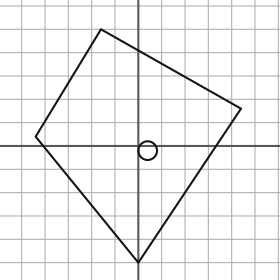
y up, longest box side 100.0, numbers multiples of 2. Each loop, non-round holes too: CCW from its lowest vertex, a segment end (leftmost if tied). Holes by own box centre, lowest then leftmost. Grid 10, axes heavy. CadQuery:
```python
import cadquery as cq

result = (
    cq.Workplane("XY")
    .moveTo(0.0, -50.0)
    .lineTo(44.0, 16.0)
    .lineTo(-16.0, 50.0)
    .lineTo(-44.0, 4.0)
    .close()
    .moveTo(4.0, -2.0)
    .circle(4.0)
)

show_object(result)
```